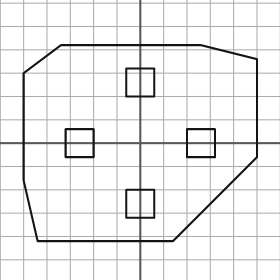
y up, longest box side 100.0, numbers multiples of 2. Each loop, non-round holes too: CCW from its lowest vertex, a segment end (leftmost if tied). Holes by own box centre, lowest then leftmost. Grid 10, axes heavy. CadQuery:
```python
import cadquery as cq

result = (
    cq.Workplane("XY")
    .moveTo(-44.0, -42.0)
    .lineTo(14.0, -42.0)
    .lineTo(50.0, -6.0)
    .lineTo(50.0, 36.0)
    .lineTo(26.0, 42.0)
    .lineTo(-34.0, 42.0)
    .lineTo(-50.0, 30.0)
    .lineTo(-50.0, -16.0)
    .close()
    .moveTo(-6.0, -32.0)
    .lineTo(6.0, -32.0)
    .lineTo(6.0, -20.0)
    .lineTo(-6.0, -20.0)
    .close()
    .moveTo(-32.0, -6.0)
    .lineTo(-20.0, -6.0)
    .lineTo(-20.0, 6.0)
    .lineTo(-32.0, 6.0)
    .close()
    .moveTo(20.0, -6.0)
    .lineTo(32.0, -6.0)
    .lineTo(32.0, 6.0)
    .lineTo(20.0, 6.0)
    .close()
    .moveTo(-6.0, 20.0)
    .lineTo(6.0, 20.0)
    .lineTo(6.0, 32.0)
    .lineTo(-6.0, 32.0)
    .close()
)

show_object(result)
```